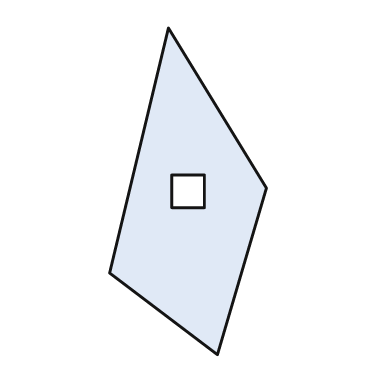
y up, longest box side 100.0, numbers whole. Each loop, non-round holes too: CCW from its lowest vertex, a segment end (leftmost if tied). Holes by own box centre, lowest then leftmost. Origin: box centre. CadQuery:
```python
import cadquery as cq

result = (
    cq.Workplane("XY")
    .moveTo(9.0, -50.0)
    .lineTo(24.0, 1.0)
    .lineTo(-6.0, 50.0)
    .lineTo(-24.0, -25.0)
    .close()
    .moveTo(-5.0, -5.0)
    .lineTo(5.0, -5.0)
    .lineTo(5.0, 5.0)
    .lineTo(-5.0, 5.0)
    .close()
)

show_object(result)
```